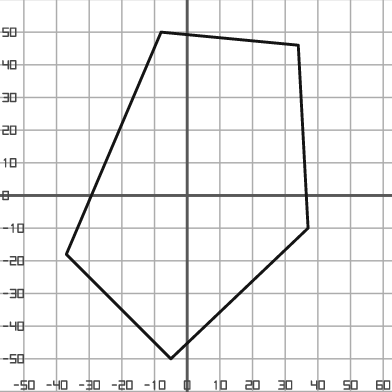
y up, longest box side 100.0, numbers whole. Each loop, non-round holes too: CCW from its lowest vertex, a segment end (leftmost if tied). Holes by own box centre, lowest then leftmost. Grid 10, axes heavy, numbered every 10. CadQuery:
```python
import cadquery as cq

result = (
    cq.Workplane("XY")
    .moveTo(-5.0, -50.0)
    .lineTo(37.0, -10.0)
    .lineTo(34.0, 46.0)
    .lineTo(-8.0, 50.0)
    .lineTo(-37.0, -18.0)
    .close()
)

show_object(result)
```